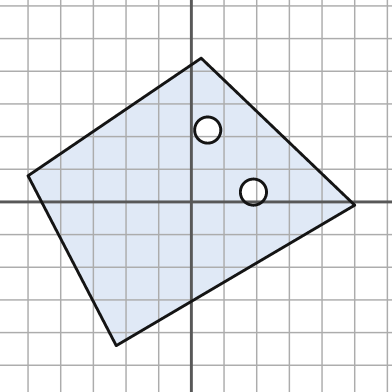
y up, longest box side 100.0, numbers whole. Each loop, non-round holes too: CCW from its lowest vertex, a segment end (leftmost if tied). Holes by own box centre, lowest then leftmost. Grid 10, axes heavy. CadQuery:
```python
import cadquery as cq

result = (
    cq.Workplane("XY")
    .moveTo(-23.0, -44.0)
    .lineTo(50.0, -1.0)
    .lineTo(3.0, 44.0)
    .lineTo(-50.0, 8.0)
    .close()
    .moveTo(19.0, 3.0)
    .circle(4.0)
    .moveTo(5.0, 22.0)
    .circle(4.0)
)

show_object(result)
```